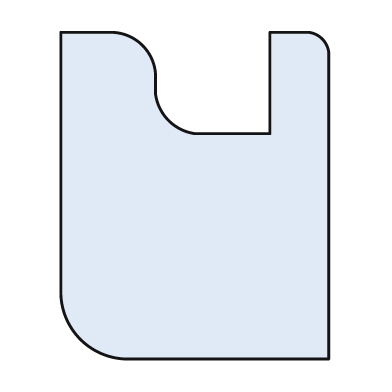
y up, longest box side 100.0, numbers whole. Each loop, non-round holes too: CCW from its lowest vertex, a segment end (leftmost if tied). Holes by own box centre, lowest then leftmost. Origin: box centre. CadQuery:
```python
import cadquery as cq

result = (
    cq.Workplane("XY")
    .moveTo(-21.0, -50.0)
    .lineTo(41.0, -50.0)
    .lineTo(41.0, 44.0)
    .threePointArc((39.0, 48.0), (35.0, 50.0))
    .lineTo(23.0, 50.0)
    .lineTo(23.0, 19.0)
    .lineTo(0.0, 19.0)
    .threePointArc((-8.0, 23.0), (-12.0, 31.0))
    .lineTo(-12.0, 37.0)
    .threePointArc((-16.0, 46.0), (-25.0, 50.0))
    .lineTo(-41.0, 50.0)
    .lineTo(-41.0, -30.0)
    .threePointArc((-35.0, -44.0), (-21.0, -50.0))
    .close()
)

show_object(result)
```